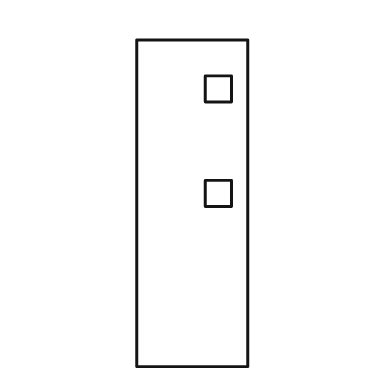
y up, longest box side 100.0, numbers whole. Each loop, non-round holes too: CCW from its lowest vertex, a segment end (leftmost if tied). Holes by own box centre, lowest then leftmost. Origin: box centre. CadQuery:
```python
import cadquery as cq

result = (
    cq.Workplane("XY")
    .moveTo(-17.0, -50.0)
    .lineTo(17.0, -50.0)
    .lineTo(17.0, 50.0)
    .lineTo(-17.0, 50.0)
    .close()
    .moveTo(4.0, -1.0)
    .lineTo(12.0, -1.0)
    .lineTo(12.0, 7.0)
    .lineTo(4.0, 7.0)
    .close()
    .moveTo(4.0, 31.0)
    .lineTo(12.0, 31.0)
    .lineTo(12.0, 39.0)
    .lineTo(4.0, 39.0)
    .close()
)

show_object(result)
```